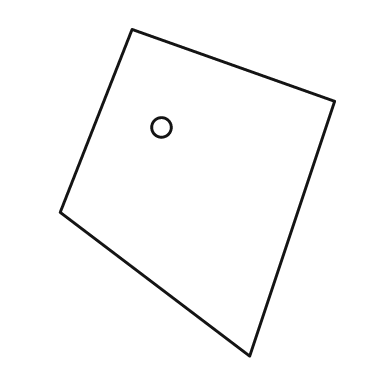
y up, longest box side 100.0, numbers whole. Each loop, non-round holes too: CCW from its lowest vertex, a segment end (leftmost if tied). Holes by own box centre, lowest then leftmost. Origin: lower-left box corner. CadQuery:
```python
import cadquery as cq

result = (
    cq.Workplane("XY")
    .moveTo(58.0, 0.0)
    .lineTo(84.0, 78.0)
    .lineTo(22.0, 100.0)
    .lineTo(0.0, 44.0)
    .close()
    .moveTo(31.0, 70.0)
    .circle(3.0)
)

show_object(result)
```